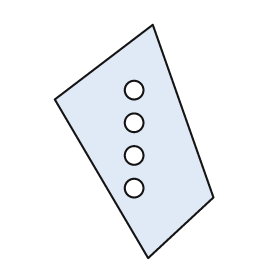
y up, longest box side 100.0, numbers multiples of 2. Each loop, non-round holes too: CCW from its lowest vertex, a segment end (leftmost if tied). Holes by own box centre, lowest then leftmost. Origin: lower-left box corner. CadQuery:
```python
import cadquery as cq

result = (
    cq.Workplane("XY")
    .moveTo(40.0, 0.0)
    .lineTo(68.0, 26.0)
    .lineTo(42.0, 100.0)
    .lineTo(0.0, 68.0)
    .close()
    .moveTo(34.0, 30.0)
    .circle(4.0)
    .moveTo(34.0, 44.0)
    .circle(4.0)
    .moveTo(34.0, 58.0)
    .circle(4.0)
    .moveTo(34.0, 72.0)
    .circle(4.0)
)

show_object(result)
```